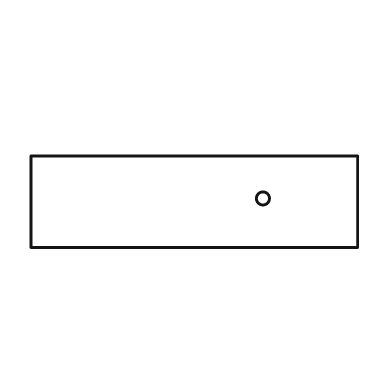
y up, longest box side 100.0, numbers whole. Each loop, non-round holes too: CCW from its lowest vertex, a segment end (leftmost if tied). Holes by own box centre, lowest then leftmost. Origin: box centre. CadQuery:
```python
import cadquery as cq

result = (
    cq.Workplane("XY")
    .moveTo(-50.0, -14.0)
    .lineTo(50.0, -14.0)
    .lineTo(50.0, 14.0)
    .lineTo(-50.0, 14.0)
    .close()
    .moveTo(21.0, 1.0)
    .circle(2.0)
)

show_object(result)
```